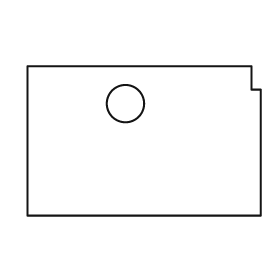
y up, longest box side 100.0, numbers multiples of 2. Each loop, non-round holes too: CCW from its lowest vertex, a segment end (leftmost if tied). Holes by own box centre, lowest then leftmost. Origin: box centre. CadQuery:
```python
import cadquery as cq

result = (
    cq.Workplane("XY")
    .moveTo(-50.0, -32.0)
    .lineTo(50.0, -32.0)
    .lineTo(50.0, 22.0)
    .lineTo(46.0, 22.0)
    .lineTo(46.0, 32.0)
    .lineTo(-50.0, 32.0)
    .close()
    .moveTo(-8.0, 16.0)
    .circle(8.0)
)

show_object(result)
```